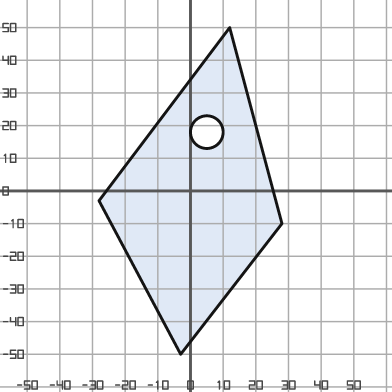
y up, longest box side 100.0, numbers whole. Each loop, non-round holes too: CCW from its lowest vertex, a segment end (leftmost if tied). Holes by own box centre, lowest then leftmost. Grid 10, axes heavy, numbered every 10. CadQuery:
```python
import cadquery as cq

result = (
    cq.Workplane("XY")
    .moveTo(-3.0, -50.0)
    .lineTo(28.0, -10.0)
    .lineTo(12.0, 50.0)
    .lineTo(-28.0, -3.0)
    .close()
    .moveTo(5.0, 18.0)
    .circle(5.0)
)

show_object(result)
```